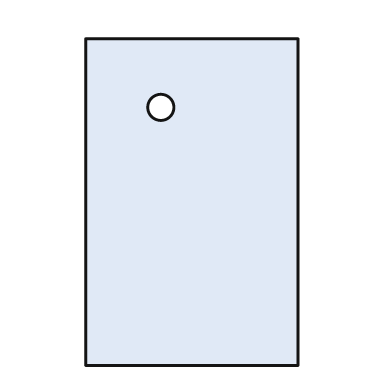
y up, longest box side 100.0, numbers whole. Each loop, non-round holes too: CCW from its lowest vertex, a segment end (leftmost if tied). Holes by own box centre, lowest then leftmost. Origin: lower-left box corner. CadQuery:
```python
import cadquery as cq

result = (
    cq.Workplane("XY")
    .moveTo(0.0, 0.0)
    .lineTo(65.0, 0.0)
    .lineTo(65.0, 100.0)
    .lineTo(0.0, 100.0)
    .close()
    .moveTo(23.0, 79.0)
    .circle(4.0)
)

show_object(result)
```